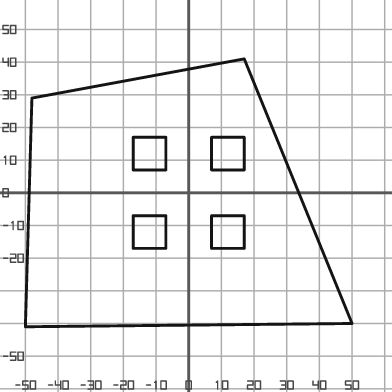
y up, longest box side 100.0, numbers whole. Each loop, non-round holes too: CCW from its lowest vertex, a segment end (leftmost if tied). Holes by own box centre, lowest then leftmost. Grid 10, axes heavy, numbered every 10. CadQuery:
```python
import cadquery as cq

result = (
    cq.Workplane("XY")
    .moveTo(-50.0, -41.0)
    .lineTo(50.0, -40.0)
    .lineTo(17.0, 41.0)
    .lineTo(-48.0, 29.0)
    .close()
    .moveTo(-17.0, -17.0)
    .lineTo(-7.0, -17.0)
    .lineTo(-7.0, -7.0)
    .lineTo(-17.0, -7.0)
    .close()
    .moveTo(7.0, -17.0)
    .lineTo(17.0, -17.0)
    .lineTo(17.0, -7.0)
    .lineTo(7.0, -7.0)
    .close()
    .moveTo(-17.0, 7.0)
    .lineTo(-7.0, 7.0)
    .lineTo(-7.0, 17.0)
    .lineTo(-17.0, 17.0)
    .close()
    .moveTo(7.0, 7.0)
    .lineTo(17.0, 7.0)
    .lineTo(17.0, 17.0)
    .lineTo(7.0, 17.0)
    .close()
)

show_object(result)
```